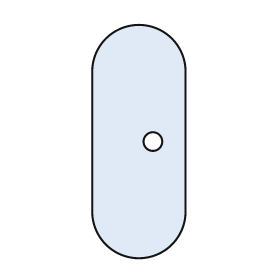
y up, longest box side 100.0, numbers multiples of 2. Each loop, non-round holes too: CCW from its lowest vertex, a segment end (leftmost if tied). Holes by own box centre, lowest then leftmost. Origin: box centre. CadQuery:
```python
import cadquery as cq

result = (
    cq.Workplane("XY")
    .moveTo(-20.0, -30.0)
    .threePointArc((0.0, -50.0), (20.0, -30.0))
    .lineTo(20.0, 30.0)
    .threePointArc((0.0, 50.0), (-20.0, 30.0))
    .close()
    .moveTo(6.0, 0.0)
    .circle(4.0)
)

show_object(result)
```